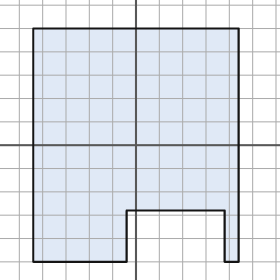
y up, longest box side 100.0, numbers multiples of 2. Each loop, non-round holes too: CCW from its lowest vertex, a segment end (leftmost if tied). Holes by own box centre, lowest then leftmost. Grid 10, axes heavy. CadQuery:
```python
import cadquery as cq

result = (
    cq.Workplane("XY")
    .moveTo(-44.0, -50.0)
    .lineTo(-4.0, -50.0)
    .lineTo(-4.0, -28.0)
    .lineTo(38.0, -28.0)
    .lineTo(38.0, -50.0)
    .lineTo(44.0, -50.0)
    .lineTo(44.0, 50.0)
    .lineTo(-44.0, 50.0)
    .close()
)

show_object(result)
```